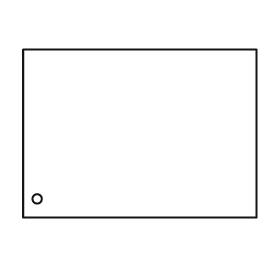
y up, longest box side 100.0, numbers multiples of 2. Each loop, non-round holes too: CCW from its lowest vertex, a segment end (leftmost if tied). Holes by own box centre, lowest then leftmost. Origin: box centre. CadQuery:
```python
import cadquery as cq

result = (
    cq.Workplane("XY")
    .moveTo(-50.0, -36.0)
    .lineTo(50.0, -36.0)
    .lineTo(50.0, 36.0)
    .lineTo(-50.0, 36.0)
    .close()
    .moveTo(-44.0, -28.0)
    .circle(2.0)
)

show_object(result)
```